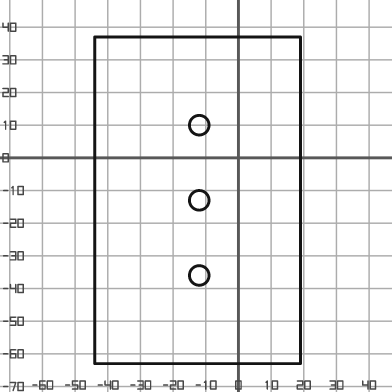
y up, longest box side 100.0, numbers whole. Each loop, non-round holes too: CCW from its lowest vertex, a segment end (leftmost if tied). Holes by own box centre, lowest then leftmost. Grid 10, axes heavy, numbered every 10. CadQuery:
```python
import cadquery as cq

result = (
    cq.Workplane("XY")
    .moveTo(-44.0, -63.0)
    .lineTo(19.0, -63.0)
    .lineTo(19.0, 37.0)
    .lineTo(-44.0, 37.0)
    .close()
    .moveTo(-12.0, -36.0)
    .circle(3.0)
    .moveTo(-12.0, -13.0)
    .circle(3.0)
    .moveTo(-12.0, 10.0)
    .circle(3.0)
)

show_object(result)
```